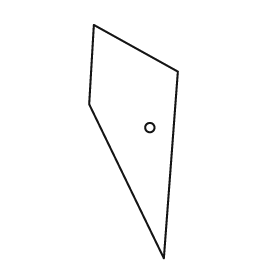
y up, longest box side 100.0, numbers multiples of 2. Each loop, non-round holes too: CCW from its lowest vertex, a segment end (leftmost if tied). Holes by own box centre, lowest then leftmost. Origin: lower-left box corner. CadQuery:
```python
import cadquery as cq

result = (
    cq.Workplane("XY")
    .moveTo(32.0, 0.0)
    .lineTo(38.0, 80.0)
    .lineTo(2.0, 100.0)
    .lineTo(0.0, 66.0)
    .close()
    .moveTo(26.0, 56.0)
    .circle(2.0)
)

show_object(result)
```